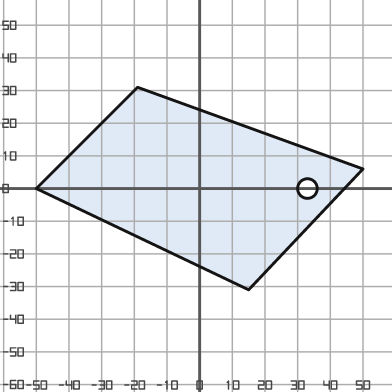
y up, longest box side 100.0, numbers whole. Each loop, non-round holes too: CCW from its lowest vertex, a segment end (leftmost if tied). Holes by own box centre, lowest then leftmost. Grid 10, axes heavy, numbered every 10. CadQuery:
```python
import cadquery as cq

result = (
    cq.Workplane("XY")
    .moveTo(15.0, -31.0)
    .lineTo(50.0, 6.0)
    .lineTo(-19.0, 31.0)
    .lineTo(-50.0, 0.0)
    .close()
    .moveTo(33.0, 0.0)
    .circle(3.0)
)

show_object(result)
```